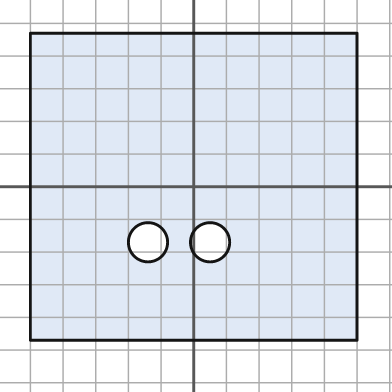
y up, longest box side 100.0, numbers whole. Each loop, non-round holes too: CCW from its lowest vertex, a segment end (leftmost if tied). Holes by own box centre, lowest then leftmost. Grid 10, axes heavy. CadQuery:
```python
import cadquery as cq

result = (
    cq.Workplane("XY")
    .moveTo(-50.0, -47.0)
    .lineTo(50.0, -47.0)
    .lineTo(50.0, 47.0)
    .lineTo(-50.0, 47.0)
    .close()
    .moveTo(-14.0, -17.0)
    .circle(6.0)
    .moveTo(5.0, -17.0)
    .circle(6.0)
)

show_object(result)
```